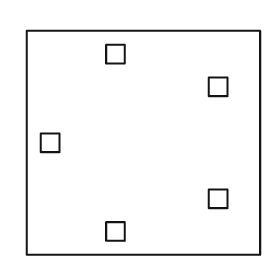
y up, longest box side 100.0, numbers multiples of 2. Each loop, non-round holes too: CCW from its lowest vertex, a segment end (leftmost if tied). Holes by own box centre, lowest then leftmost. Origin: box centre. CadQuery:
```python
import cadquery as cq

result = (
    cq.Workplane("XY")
    .moveTo(-50.0, -48.0)
    .lineTo(50.0, -48.0)
    .lineTo(50.0, 48.0)
    .lineTo(-50.0, 48.0)
    .close()
    .moveTo(-16.0, -42.0)
    .lineTo(-8.0, -42.0)
    .lineTo(-8.0, -34.0)
    .lineTo(-16.0, -34.0)
    .close()
    .moveTo(28.0, -28.0)
    .lineTo(36.0, -28.0)
    .lineTo(36.0, -20.0)
    .lineTo(28.0, -20.0)
    .close()
    .moveTo(-44.0, -4.0)
    .lineTo(-36.0, -4.0)
    .lineTo(-36.0, 4.0)
    .lineTo(-44.0, 4.0)
    .close()
    .moveTo(28.0, 20.0)
    .lineTo(36.0, 20.0)
    .lineTo(36.0, 28.0)
    .lineTo(28.0, 28.0)
    .close()
    .moveTo(-16.0, 34.0)
    .lineTo(-8.0, 34.0)
    .lineTo(-8.0, 42.0)
    .lineTo(-16.0, 42.0)
    .close()
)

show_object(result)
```